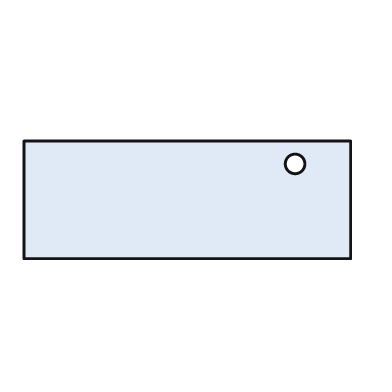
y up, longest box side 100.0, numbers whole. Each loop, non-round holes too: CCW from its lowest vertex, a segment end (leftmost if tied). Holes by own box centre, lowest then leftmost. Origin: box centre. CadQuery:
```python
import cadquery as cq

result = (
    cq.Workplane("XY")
    .moveTo(-50.0, -18.0)
    .lineTo(50.0, -18.0)
    .lineTo(50.0, 18.0)
    .lineTo(-50.0, 18.0)
    .close()
    .moveTo(33.0, 11.0)
    .circle(3.0)
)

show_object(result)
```